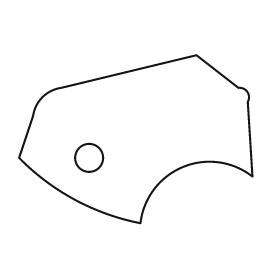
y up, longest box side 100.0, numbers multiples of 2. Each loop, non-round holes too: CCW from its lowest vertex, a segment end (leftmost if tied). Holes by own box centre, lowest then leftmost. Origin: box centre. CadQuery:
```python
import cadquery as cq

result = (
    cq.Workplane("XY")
    .moveTo(2.0, -36.0)
    .threePointArc((20.0, -12.0), (50.0, -16.0))
    .lineTo(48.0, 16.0)
    .threePointArc((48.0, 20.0), (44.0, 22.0))
    .lineTo(26.0, 36.0)
    .lineTo(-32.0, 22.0)
    .threePointArc((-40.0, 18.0), (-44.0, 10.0))
    .lineTo(-50.0, -8.0)
    .threePointArc((-26.0, -26.0), (2.0, -36.0))
    .close()
    .moveTo(-20.0, -8.0)
    .circle(6.0)
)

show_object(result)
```